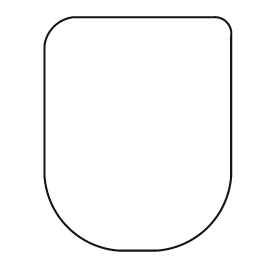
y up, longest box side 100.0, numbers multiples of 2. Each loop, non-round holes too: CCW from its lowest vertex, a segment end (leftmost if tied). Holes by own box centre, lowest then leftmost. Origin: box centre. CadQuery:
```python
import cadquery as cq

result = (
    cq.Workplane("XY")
    .moveTo(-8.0, -50.0)
    .lineTo(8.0, -50.0)
    .threePointArc((30.0, -40.0), (40.0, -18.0))
    .lineTo(40.0, 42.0)
    .threePointArc((38.0, 48.0), (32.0, 50.0))
    .lineTo(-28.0, 50.0)
    .threePointArc((-36.0, 46.0), (-40.0, 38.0))
    .lineTo(-40.0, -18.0)
    .threePointArc((-30.0, -40.0), (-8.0, -50.0))
    .close()
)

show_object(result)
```